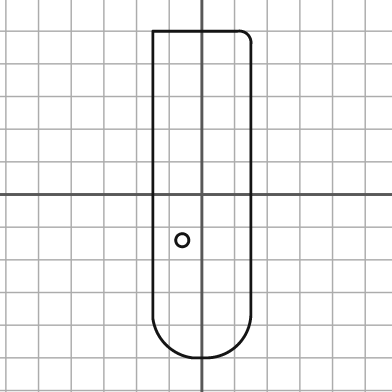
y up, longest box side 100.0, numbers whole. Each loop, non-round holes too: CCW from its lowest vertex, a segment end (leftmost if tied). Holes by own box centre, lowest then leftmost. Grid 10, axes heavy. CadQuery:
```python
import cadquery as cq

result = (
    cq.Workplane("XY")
    .moveTo(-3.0, -50.0)
    .lineTo(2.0, -50.0)
    .threePointArc((11.0, -46.0), (15.0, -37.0))
    .lineTo(15.0, 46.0)
    .threePointArc((14.0, 49.0), (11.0, 50.0))
    .lineTo(-15.0, 50.0)
    .lineTo(-15.0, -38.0)
    .threePointArc((-11.0, -46.0), (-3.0, -50.0))
    .close()
    .moveTo(-6.0, -14.0)
    .circle(2.0)
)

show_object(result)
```